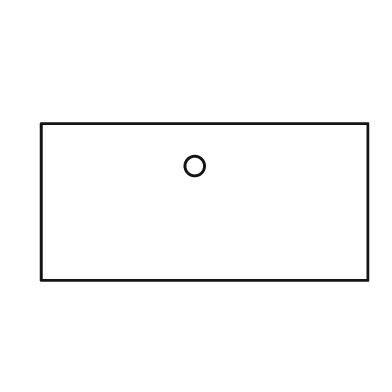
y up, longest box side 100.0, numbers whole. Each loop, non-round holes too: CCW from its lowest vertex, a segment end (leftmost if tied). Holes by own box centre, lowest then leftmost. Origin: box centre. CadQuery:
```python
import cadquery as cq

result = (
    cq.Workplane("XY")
    .moveTo(-50.0, -24.0)
    .lineTo(50.0, -24.0)
    .lineTo(50.0, 24.0)
    .lineTo(-50.0, 24.0)
    .close()
    .moveTo(-3.0, 11.0)
    .circle(3.0)
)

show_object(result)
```